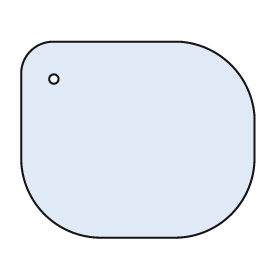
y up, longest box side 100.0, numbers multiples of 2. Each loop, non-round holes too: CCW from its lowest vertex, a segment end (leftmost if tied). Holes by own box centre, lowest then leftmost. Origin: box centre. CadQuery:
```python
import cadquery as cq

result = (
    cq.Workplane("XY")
    .moveTo(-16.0, -42.0)
    .lineTo(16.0, -42.0)
    .threePointArc((40.0, -32.0), (50.0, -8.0))
    .lineTo(50.0, 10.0)
    .threePointArc((40.0, 32.0), (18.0, 42.0))
    .lineTo(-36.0, 42.0)
    .threePointArc((-46.0, 38.0), (-50.0, 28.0))
    .lineTo(-50.0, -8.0)
    .threePointArc((-40.0, -32.0), (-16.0, -42.0))
    .close()
    .moveTo(-36.0, 26.0)
    .circle(2.0)
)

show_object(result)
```